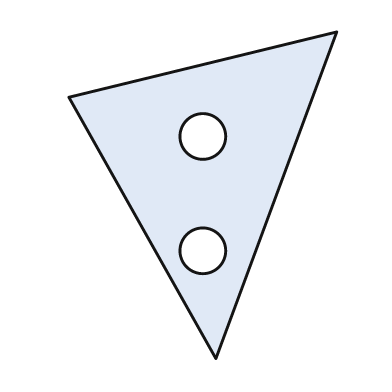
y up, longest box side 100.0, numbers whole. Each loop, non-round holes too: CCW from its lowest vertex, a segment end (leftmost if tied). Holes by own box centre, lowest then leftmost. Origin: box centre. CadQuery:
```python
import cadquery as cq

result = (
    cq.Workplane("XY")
    .moveTo(4.0, -50.0)
    .lineTo(41.0, 50.0)
    .lineTo(-41.0, 30.0)
    .close()
    .moveTo(0.0, -17.0)
    .circle(7.0)
    .moveTo(0.0, 18.0)
    .circle(7.0)
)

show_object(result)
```